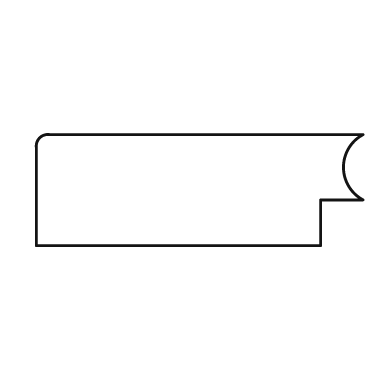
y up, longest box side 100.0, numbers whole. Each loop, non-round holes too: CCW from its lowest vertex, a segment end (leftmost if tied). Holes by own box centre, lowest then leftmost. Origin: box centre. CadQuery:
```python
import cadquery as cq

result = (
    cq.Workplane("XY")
    .moveTo(-50.0, -17.0)
    .lineTo(37.0, -17.0)
    .lineTo(37.0, -3.0)
    .lineTo(50.0, -3.0)
    .threePointArc((44.0, 7.0), (50.0, 17.0))
    .lineTo(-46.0, 17.0)
    .threePointArc((-49.0, 16.0), (-50.0, 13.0))
    .close()
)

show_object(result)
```